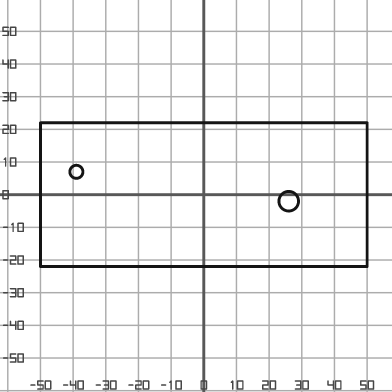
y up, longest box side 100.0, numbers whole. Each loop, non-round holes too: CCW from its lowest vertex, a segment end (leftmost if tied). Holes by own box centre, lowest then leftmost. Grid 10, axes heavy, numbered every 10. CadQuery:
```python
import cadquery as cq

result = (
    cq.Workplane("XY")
    .moveTo(-50.0, -22.0)
    .lineTo(50.0, -22.0)
    .lineTo(50.0, 22.0)
    .lineTo(-50.0, 22.0)
    .close()
    .moveTo(26.0, -2.0)
    .circle(3.0)
    .moveTo(-39.0, 7.0)
    .circle(2.0)
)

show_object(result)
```